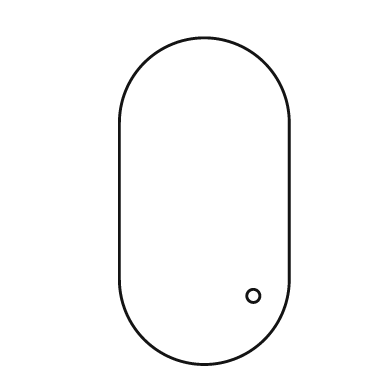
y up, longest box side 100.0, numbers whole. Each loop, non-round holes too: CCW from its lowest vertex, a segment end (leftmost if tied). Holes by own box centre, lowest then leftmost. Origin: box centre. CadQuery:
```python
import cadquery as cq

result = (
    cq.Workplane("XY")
    .moveTo(-26.0, -24.0)
    .threePointArc((0.0, -50.0), (26.0, -24.0))
    .lineTo(26.0, 24.0)
    .threePointArc((0.0, 50.0), (-26.0, 24.0))
    .close()
    .moveTo(15.0, -29.0)
    .circle(2.0)
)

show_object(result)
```